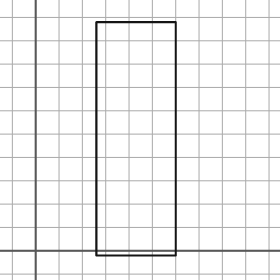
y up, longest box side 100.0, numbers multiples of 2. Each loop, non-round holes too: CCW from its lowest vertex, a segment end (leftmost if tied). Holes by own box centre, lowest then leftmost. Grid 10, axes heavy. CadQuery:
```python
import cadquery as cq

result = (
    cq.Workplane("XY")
    .moveTo(26.0, -2.0)
    .lineTo(60.0, -2.0)
    .lineTo(60.0, 98.0)
    .lineTo(26.0, 98.0)
    .close()
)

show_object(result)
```